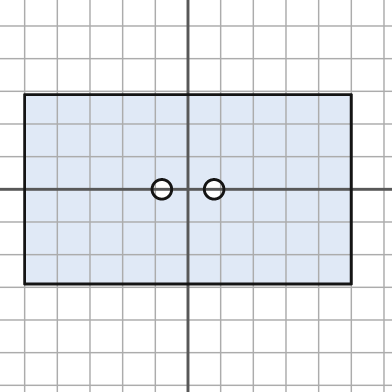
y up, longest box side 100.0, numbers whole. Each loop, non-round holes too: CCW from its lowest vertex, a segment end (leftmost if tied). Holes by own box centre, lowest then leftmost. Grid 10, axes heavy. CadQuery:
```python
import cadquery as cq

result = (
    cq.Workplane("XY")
    .moveTo(-50.0, -29.0)
    .lineTo(50.0, -29.0)
    .lineTo(50.0, 29.0)
    .lineTo(-50.0, 29.0)
    .close()
    .moveTo(-8.0, 0.0)
    .circle(3.0)
    .moveTo(8.0, 0.0)
    .circle(3.0)
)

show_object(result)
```